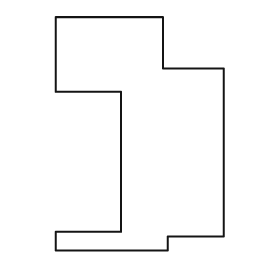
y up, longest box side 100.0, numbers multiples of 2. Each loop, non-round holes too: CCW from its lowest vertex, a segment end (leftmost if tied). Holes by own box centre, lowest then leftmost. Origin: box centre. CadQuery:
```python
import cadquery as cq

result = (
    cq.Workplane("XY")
    .moveTo(-36.0, -50.0)
    .lineTo(12.0, -50.0)
    .lineTo(12.0, -44.0)
    .lineTo(36.0, -44.0)
    .lineTo(36.0, 28.0)
    .lineTo(10.0, 28.0)
    .lineTo(10.0, 50.0)
    .lineTo(-36.0, 50.0)
    .lineTo(-36.0, 18.0)
    .lineTo(-8.0, 18.0)
    .lineTo(-8.0, -42.0)
    .lineTo(-36.0, -42.0)
    .close()
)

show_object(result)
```